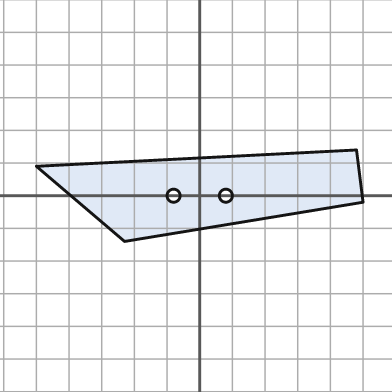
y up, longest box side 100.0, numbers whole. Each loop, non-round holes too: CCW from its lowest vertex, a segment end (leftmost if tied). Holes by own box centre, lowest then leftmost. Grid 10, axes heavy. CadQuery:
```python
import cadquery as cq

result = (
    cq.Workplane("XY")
    .moveTo(-23.0, -14.0)
    .lineTo(50.0, -2.0)
    .lineTo(48.0, 14.0)
    .lineTo(-50.0, 9.0)
    .close()
    .moveTo(-8.0, 0.0)
    .circle(2.0)
    .moveTo(8.0, 0.0)
    .circle(2.0)
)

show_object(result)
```